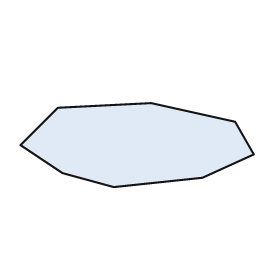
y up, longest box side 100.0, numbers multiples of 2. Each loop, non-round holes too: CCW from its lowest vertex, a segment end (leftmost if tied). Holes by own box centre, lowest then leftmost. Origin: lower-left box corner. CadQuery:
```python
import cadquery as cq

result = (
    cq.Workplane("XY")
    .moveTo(40.0, 0.0)
    .lineTo(78.0, 4.0)
    .lineTo(100.0, 14.0)
    .lineTo(92.0, 28.0)
    .lineTo(56.0, 36.0)
    .lineTo(16.0, 34.0)
    .lineTo(0.0, 18.0)
    .lineTo(18.0, 6.0)
    .close()
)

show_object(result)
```